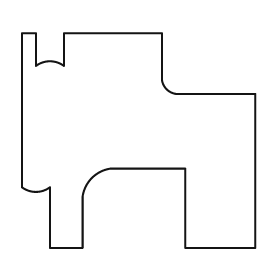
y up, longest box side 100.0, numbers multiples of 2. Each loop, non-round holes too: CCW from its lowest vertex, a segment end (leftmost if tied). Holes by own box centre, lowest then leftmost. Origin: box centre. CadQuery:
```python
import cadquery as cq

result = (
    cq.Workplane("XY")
    .moveTo(-38.0, -46.0)
    .lineTo(-24.0, -46.0)
    .lineTo(-24.0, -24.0)
    .threePointArc((-20.0, -16.0), (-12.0, -12.0))
    .lineTo(20.0, -12.0)
    .lineTo(20.0, -46.0)
    .lineTo(50.0, -46.0)
    .lineTo(50.0, 20.0)
    .lineTo(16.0, 20.0)
    .threePointArc((12.0, 22.0), (10.0, 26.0))
    .lineTo(10.0, 46.0)
    .lineTo(-32.0, 46.0)
    .lineTo(-32.0, 32.0)
    .threePointArc((-38.0, 34.0), (-44.0, 32.0))
    .lineTo(-44.0, 46.0)
    .lineTo(-50.0, 46.0)
    .lineTo(-50.0, -20.0)
    .threePointArc((-44.0, -22.0), (-38.0, -20.0))
    .close()
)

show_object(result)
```